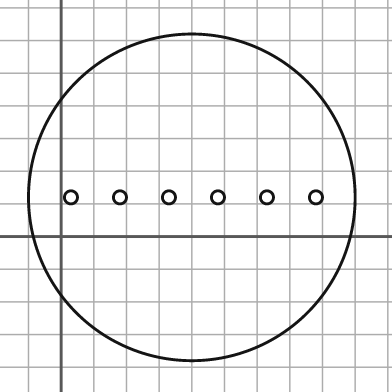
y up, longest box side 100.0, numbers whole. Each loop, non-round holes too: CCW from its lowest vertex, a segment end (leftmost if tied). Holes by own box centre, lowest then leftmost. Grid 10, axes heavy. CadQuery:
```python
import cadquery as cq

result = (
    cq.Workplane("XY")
    .moveTo(40.0, 12.0)
    .circle(50.0)
    .moveTo(3.0, 12.0)
    .circle(2.0)
    .moveTo(18.0, 12.0)
    .circle(2.0)
    .moveTo(33.0, 12.0)
    .circle(2.0)
    .moveTo(48.0, 12.0)
    .circle(2.0)
    .moveTo(63.0, 12.0)
    .circle(2.0)
    .moveTo(78.0, 12.0)
    .circle(2.0)
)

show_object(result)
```